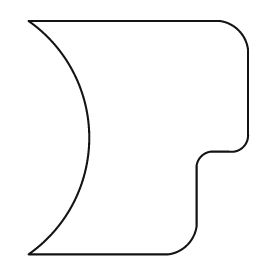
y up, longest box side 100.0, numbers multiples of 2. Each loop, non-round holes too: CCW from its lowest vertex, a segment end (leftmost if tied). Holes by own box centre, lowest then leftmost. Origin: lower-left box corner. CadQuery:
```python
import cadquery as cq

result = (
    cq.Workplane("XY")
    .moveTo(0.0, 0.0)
    .lineTo(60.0, 0.0)
    .threePointArc((68.0, 4.0), (72.0, 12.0))
    .lineTo(72.0, 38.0)
    .threePointArc((74.0, 42.0), (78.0, 44.0))
    .lineTo(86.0, 44.0)
    .threePointArc((92.0, 46.0), (94.0, 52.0))
    .lineTo(94.0, 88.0)
    .threePointArc((90.0, 96.0), (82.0, 100.0))
    .lineTo(0.0, 100.0)
    .threePointArc((26.0, 50.0), (0.0, 0.0))
    .close()
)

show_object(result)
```